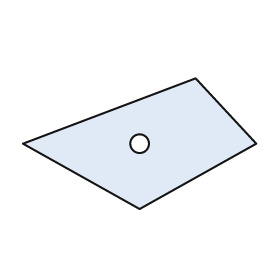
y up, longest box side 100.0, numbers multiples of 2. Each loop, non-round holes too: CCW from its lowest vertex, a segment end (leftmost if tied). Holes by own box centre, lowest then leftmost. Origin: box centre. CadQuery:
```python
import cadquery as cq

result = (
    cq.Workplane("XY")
    .moveTo(0.0, -28.0)
    .lineTo(50.0, 0.0)
    .lineTo(24.0, 28.0)
    .lineTo(-50.0, 0.0)
    .close()
    .moveTo(0.0, 0.0)
    .circle(4.0)
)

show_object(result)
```